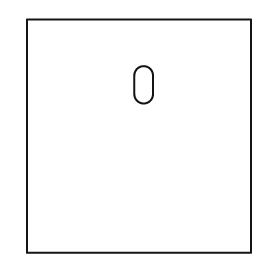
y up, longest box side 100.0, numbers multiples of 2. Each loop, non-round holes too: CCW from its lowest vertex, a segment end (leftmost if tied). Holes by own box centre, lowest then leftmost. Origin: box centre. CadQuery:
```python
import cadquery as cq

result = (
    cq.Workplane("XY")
    .moveTo(-48.0, -50.0)
    .lineTo(48.0, -50.0)
    .lineTo(48.0, 50.0)
    .lineTo(-48.0, 50.0)
    .close()
    .moveTo(-2.0, 18.0)
    .threePointArc((2.0, 14.0), (6.0, 18.0))
    .lineTo(6.0, 26.0)
    .threePointArc((2.0, 30.0), (-2.0, 26.0))
    .close()
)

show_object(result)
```